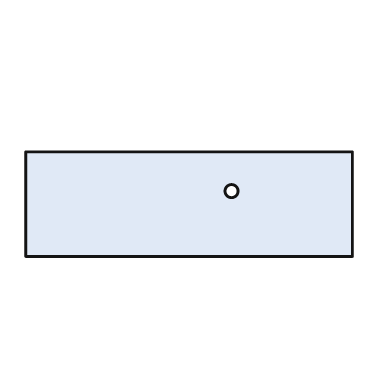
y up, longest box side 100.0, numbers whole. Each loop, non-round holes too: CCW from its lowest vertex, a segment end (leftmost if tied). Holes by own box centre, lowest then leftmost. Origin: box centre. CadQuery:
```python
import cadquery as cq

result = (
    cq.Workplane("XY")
    .moveTo(-50.0, -16.0)
    .lineTo(50.0, -16.0)
    .lineTo(50.0, 16.0)
    .lineTo(-50.0, 16.0)
    .close()
    .moveTo(13.0, 4.0)
    .circle(2.0)
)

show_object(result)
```